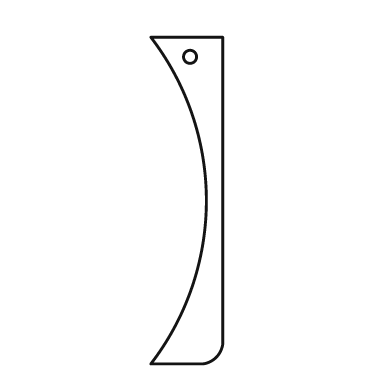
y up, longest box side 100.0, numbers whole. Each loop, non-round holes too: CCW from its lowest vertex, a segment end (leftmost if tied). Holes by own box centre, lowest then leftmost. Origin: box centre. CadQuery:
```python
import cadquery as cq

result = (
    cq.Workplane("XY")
    .moveTo(-11.0, -50.0)
    .lineTo(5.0, -50.0)
    .threePointArc((9.0, -48.0), (11.0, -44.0))
    .lineTo(11.0, 50.0)
    .lineTo(-11.0, 50.0)
    .threePointArc((6.0, 0.0), (-11.0, -50.0))
    .close()
    .moveTo(1.0, 44.0)
    .circle(2.0)
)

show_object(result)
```